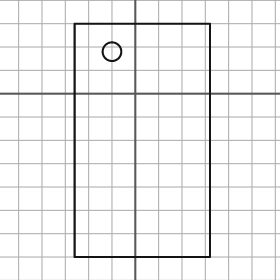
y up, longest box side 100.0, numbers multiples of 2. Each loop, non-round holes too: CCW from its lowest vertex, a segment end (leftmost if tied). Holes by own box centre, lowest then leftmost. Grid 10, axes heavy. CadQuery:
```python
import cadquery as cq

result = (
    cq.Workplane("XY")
    .moveTo(-26.0, -70.0)
    .lineTo(32.0, -70.0)
    .lineTo(32.0, 30.0)
    .lineTo(-26.0, 30.0)
    .close()
    .moveTo(-10.0, 18.0)
    .circle(4.0)
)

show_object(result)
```